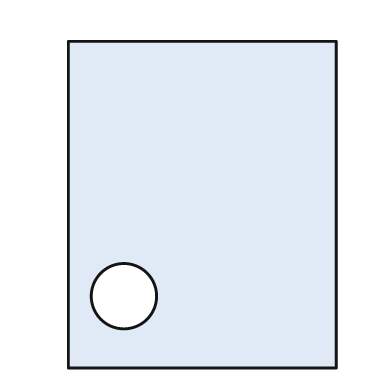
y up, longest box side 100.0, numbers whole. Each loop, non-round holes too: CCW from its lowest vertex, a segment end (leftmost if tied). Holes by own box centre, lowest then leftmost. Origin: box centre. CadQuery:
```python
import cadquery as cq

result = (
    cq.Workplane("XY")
    .moveTo(-41.0, -50.0)
    .lineTo(41.0, -50.0)
    .lineTo(41.0, 50.0)
    .lineTo(-41.0, 50.0)
    .close()
    .moveTo(-24.0, -28.0)
    .circle(10.0)
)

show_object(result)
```